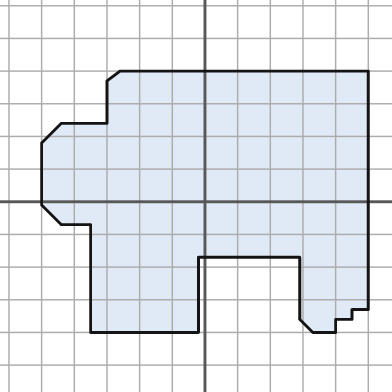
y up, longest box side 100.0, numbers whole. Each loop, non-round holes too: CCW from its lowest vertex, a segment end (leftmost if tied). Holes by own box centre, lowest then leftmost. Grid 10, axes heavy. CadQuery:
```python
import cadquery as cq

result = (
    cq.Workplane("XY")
    .moveTo(-35.0, -40.0)
    .lineTo(-2.0, -40.0)
    .lineTo(-2.0, -17.0)
    .lineTo(29.0, -17.0)
    .lineTo(29.0, -36.0)
    .lineTo(33.0, -40.0)
    .lineTo(40.0, -40.0)
    .lineTo(40.0, -36.0)
    .lineTo(45.0, -36.0)
    .lineTo(45.0, -33.0)
    .lineTo(50.0, -33.0)
    .lineTo(50.0, 40.0)
    .lineTo(-26.0, 40.0)
    .lineTo(-30.0, 37.0)
    .lineTo(-30.0, 24.0)
    .lineTo(-44.0, 24.0)
    .lineTo(-50.0, 18.0)
    .lineTo(-50.0, -1.0)
    .lineTo(-44.0, -7.0)
    .lineTo(-35.0, -7.0)
    .close()
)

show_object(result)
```